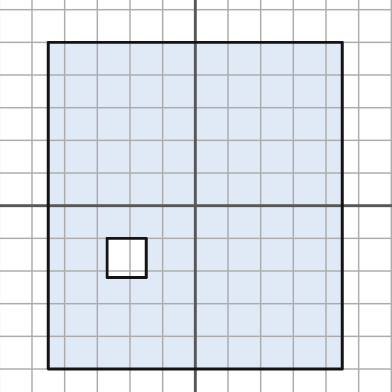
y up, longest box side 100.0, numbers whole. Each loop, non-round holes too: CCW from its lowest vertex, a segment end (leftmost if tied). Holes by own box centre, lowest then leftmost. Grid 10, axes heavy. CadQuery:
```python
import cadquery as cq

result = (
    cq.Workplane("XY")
    .moveTo(-45.0, -50.0)
    .lineTo(45.0, -50.0)
    .lineTo(45.0, 50.0)
    .lineTo(-45.0, 50.0)
    .close()
    .moveTo(-27.0, -22.0)
    .lineTo(-15.0, -22.0)
    .lineTo(-15.0, -10.0)
    .lineTo(-27.0, -10.0)
    .close()
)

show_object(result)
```